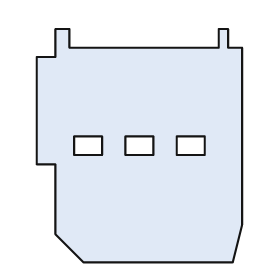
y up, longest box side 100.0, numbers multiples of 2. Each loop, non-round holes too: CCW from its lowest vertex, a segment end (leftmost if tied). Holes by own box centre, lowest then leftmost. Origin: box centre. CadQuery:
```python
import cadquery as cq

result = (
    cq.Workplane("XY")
    .moveTo(-24.0, -50.0)
    .lineTo(40.0, -50.0)
    .lineTo(44.0, -34.0)
    .lineTo(44.0, 42.0)
    .lineTo(38.0, 42.0)
    .lineTo(38.0, 50.0)
    .lineTo(34.0, 50.0)
    .lineTo(34.0, 42.0)
    .lineTo(-30.0, 42.0)
    .lineTo(-30.0, 50.0)
    .lineTo(-36.0, 50.0)
    .lineTo(-36.0, 38.0)
    .lineTo(-44.0, 38.0)
    .lineTo(-44.0, -8.0)
    .lineTo(-36.0, -8.0)
    .lineTo(-36.0, -38.0)
    .close()
    .moveTo(-28.0, -4.0)
    .lineTo(-16.0, -4.0)
    .lineTo(-16.0, 4.0)
    .lineTo(-28.0, 4.0)
    .close()
    .moveTo(-6.0, -4.0)
    .lineTo(6.0, -4.0)
    .lineTo(6.0, 4.0)
    .lineTo(-6.0, 4.0)
    .close()
    .moveTo(16.0, -4.0)
    .lineTo(28.0, -4.0)
    .lineTo(28.0, 4.0)
    .lineTo(16.0, 4.0)
    .close()
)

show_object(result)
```